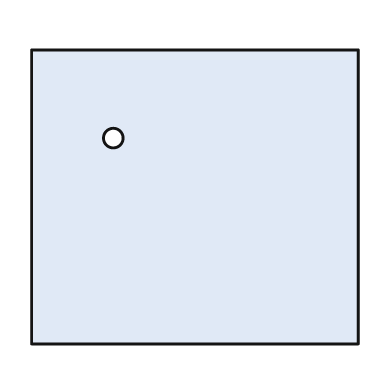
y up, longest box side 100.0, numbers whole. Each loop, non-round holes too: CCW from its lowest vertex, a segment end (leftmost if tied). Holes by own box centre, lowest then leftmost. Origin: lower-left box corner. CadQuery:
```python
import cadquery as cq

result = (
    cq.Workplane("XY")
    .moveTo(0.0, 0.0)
    .lineTo(100.0, 0.0)
    .lineTo(100.0, 90.0)
    .lineTo(0.0, 90.0)
    .close()
    .moveTo(25.0, 63.0)
    .circle(3.0)
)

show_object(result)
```